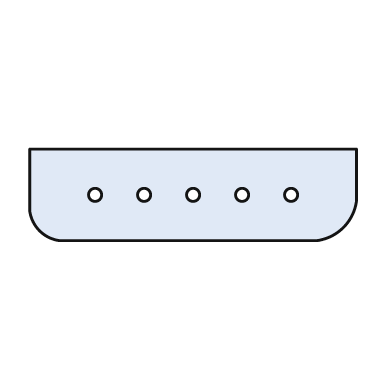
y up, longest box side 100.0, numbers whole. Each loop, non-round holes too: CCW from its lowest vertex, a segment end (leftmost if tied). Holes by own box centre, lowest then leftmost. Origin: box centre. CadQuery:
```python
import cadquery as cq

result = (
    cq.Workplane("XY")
    .moveTo(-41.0, -14.0)
    .lineTo(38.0, -14.0)
    .threePointArc((46.0, -10.0), (50.0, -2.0))
    .lineTo(50.0, 14.0)
    .lineTo(-50.0, 14.0)
    .lineTo(-50.0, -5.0)
    .threePointArc((-47.0, -11.0), (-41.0, -14.0))
    .close()
    .moveTo(-30.0, 0.0)
    .circle(2.0)
    .moveTo(-15.0, 0.0)
    .circle(2.0)
    .moveTo(0.0, 0.0)
    .circle(2.0)
    .moveTo(15.0, 0.0)
    .circle(2.0)
    .moveTo(30.0, 0.0)
    .circle(2.0)
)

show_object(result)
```